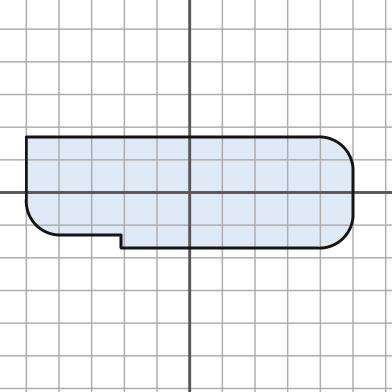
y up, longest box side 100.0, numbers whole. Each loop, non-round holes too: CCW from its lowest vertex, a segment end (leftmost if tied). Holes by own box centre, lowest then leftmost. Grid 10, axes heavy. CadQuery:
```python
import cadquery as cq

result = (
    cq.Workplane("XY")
    .moveTo(-21.0, -17.0)
    .lineTo(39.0, -17.0)
    .threePointArc((47.0, -14.0), (50.0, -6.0))
    .lineTo(50.0, 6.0)
    .threePointArc((47.0, 14.0), (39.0, 17.0))
    .lineTo(-50.0, 17.0)
    .lineTo(-50.0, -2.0)
    .threePointArc((-47.0, -10.0), (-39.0, -13.0))
    .lineTo(-21.0, -13.0)
    .close()
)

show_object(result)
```